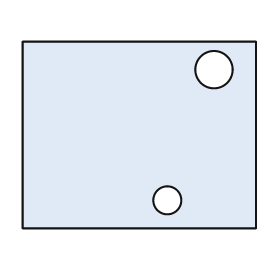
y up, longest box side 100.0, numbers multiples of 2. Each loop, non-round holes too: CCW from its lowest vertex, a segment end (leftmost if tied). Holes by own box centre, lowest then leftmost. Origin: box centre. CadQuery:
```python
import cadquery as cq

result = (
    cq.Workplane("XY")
    .moveTo(-50.0, -40.0)
    .lineTo(50.0, -40.0)
    .lineTo(50.0, 40.0)
    .lineTo(-50.0, 40.0)
    .close()
    .moveTo(12.0, -28.0)
    .circle(6.0)
    .moveTo(32.0, 28.0)
    .circle(8.0)
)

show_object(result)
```